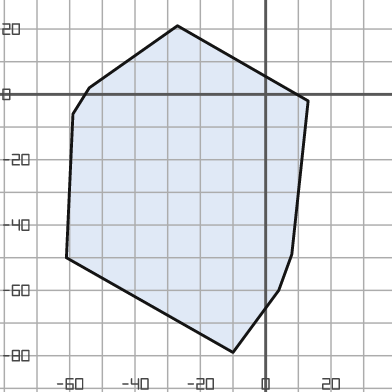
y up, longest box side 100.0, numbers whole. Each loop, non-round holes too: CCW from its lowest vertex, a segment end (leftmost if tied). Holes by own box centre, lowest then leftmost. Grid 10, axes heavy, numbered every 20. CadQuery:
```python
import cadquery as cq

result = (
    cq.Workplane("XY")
    .moveTo(-10.0, -79.0)
    .lineTo(4.0, -60.0)
    .lineTo(8.0, -49.0)
    .lineTo(13.0, -2.0)
    .lineTo(-27.0, 21.0)
    .lineTo(-54.0, 2.0)
    .lineTo(-59.0, -6.0)
    .lineTo(-61.0, -50.0)
    .close()
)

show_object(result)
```